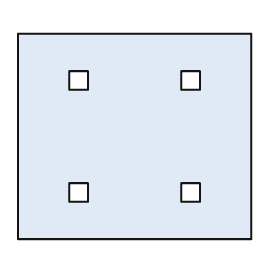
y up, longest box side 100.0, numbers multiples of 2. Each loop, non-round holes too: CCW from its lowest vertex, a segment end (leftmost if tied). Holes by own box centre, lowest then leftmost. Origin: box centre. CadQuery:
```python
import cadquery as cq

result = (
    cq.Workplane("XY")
    .moveTo(-50.0, -44.0)
    .lineTo(50.0, -44.0)
    .lineTo(50.0, 44.0)
    .lineTo(-50.0, 44.0)
    .close()
    .moveTo(-28.0, -28.0)
    .lineTo(-20.0, -28.0)
    .lineTo(-20.0, -20.0)
    .lineTo(-28.0, -20.0)
    .close()
    .moveTo(20.0, -28.0)
    .lineTo(28.0, -28.0)
    .lineTo(28.0, -20.0)
    .lineTo(20.0, -20.0)
    .close()
    .moveTo(-28.0, 20.0)
    .lineTo(-20.0, 20.0)
    .lineTo(-20.0, 28.0)
    .lineTo(-28.0, 28.0)
    .close()
    .moveTo(20.0, 20.0)
    .lineTo(28.0, 20.0)
    .lineTo(28.0, 28.0)
    .lineTo(20.0, 28.0)
    .close()
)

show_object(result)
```